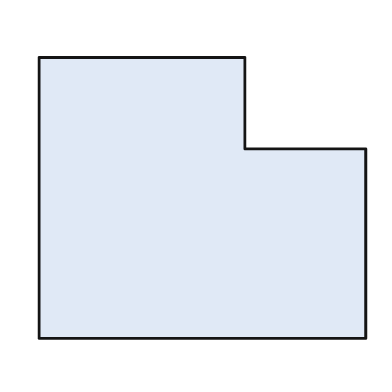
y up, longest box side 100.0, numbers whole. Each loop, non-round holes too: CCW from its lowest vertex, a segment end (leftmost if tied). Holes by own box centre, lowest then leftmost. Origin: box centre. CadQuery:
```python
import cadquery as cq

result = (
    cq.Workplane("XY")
    .moveTo(-50.0, -43.0)
    .lineTo(50.0, -43.0)
    .lineTo(50.0, 15.0)
    .lineTo(13.0, 15.0)
    .lineTo(13.0, 43.0)
    .lineTo(-50.0, 43.0)
    .close()
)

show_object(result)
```